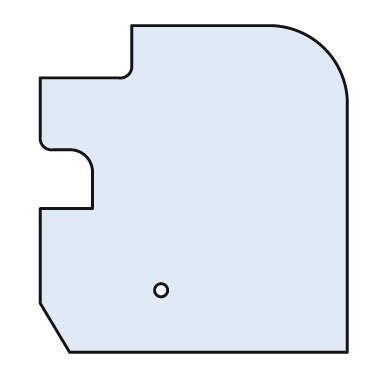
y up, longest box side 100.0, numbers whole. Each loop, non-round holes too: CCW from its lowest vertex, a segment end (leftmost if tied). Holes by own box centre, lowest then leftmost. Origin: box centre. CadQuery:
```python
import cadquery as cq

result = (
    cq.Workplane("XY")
    .moveTo(-38.0, -50.0)
    .lineTo(47.0, -50.0)
    .lineTo(47.0, 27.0)
    .threePointArc((40.0, 43.0), (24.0, 50.0))
    .lineTo(-19.0, 50.0)
    .lineTo(-19.0, 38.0)
    .threePointArc((-20.0, 35.0), (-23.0, 34.0))
    .lineTo(-47.0, 34.0)
    .lineTo(-47.0, 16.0)
    .threePointArc((-46.0, 13.0), (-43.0, 12.0))
    .lineTo(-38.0, 12.0)
    .threePointArc((-33.0, 10.0), (-31.0, 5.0))
    .lineTo(-31.0, -6.0)
    .lineTo(-47.0, -6.0)
    .lineTo(-47.0, -35.0)
    .close()
    .moveTo(-10.0, -31.0)
    .circle(2.0)
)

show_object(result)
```